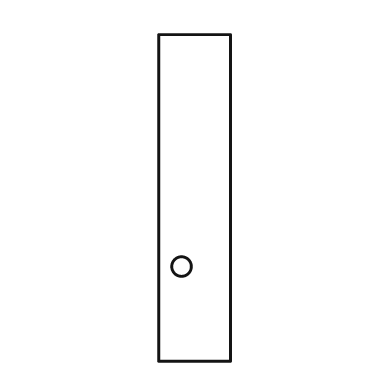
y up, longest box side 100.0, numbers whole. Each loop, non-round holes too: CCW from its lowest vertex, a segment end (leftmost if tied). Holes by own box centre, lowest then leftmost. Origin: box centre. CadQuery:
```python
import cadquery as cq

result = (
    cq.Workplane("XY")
    .moveTo(-11.0, -50.0)
    .lineTo(11.0, -50.0)
    .lineTo(11.0, 50.0)
    .lineTo(-11.0, 50.0)
    .close()
    .moveTo(-4.0, -21.0)
    .circle(3.0)
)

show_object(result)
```